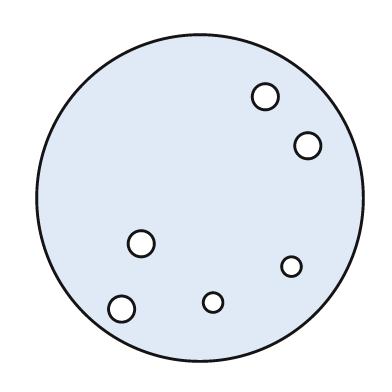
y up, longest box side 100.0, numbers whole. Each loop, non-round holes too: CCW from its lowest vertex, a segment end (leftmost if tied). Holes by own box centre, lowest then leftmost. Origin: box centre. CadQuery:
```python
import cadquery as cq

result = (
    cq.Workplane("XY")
    .moveTo(0.0, 0.0)
    .circle(50.0)
    .moveTo(-24.0, -34.0)
    .circle(4.0)
    .moveTo(4.0, -32.0)
    .circle(3.0)
    .moveTo(28.0, -21.0)
    .circle(3.0)
    .moveTo(-18.0, -14.0)
    .circle(4.0)
    .moveTo(33.0, 16.0)
    .circle(4.0)
    .moveTo(20.0, 31.0)
    .circle(4.0)
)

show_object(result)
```